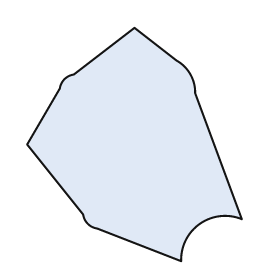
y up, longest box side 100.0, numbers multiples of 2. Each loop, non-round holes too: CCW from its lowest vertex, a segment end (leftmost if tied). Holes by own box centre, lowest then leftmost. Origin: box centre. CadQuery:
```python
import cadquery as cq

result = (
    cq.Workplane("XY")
    .moveTo(20.0, -50.0)
    .threePointArc((28.0, -34.0), (46.0, -32.0))
    .lineTo(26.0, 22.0)
    .threePointArc((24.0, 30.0), (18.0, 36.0))
    .lineTo(0.0, 50.0)
    .lineTo(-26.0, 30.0)
    .threePointArc((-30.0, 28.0), (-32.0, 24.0))
    .lineTo(-46.0, 0.0)
    .lineTo(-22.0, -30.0)
    .threePointArc((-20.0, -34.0), (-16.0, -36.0))
    .close()
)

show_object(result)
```